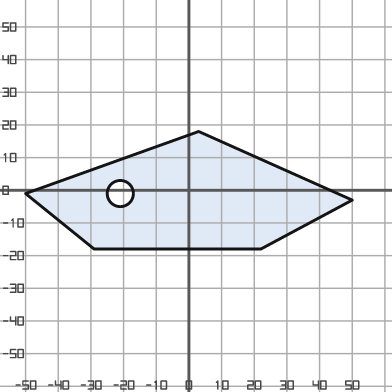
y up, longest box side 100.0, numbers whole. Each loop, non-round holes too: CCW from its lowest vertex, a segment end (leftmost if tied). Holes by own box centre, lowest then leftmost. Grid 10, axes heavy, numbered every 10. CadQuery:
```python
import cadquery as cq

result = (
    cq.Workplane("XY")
    .moveTo(-29.0, -18.0)
    .lineTo(22.0, -18.0)
    .lineTo(50.0, -3.0)
    .lineTo(3.0, 18.0)
    .lineTo(-50.0, -1.0)
    .close()
    .moveTo(-21.0, -1.0)
    .circle(4.0)
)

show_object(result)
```